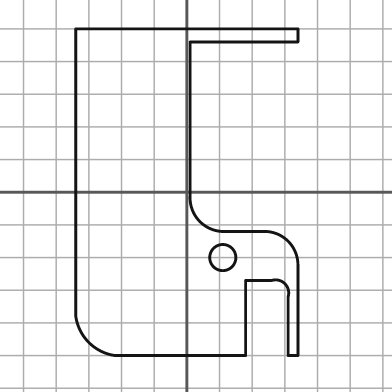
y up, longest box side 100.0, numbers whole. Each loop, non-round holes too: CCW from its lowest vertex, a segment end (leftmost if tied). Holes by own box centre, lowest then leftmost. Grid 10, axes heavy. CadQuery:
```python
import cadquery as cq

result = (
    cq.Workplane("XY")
    .moveTo(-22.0, -50.0)
    .lineTo(18.0, -50.0)
    .lineTo(18.0, -27.0)
    .lineTo(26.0, -27.0)
    .threePointArc((30.0, -28.0), (31.0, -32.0))
    .lineTo(31.0, -50.0)
    .lineTo(34.0, -50.0)
    .lineTo(34.0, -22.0)
    .threePointArc((31.0, -15.0), (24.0, -12.0))
    .lineTo(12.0, -12.0)
    .threePointArc((4.0, -9.0), (1.0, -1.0))
    .lineTo(1.0, 46.0)
    .lineTo(34.0, 46.0)
    .lineTo(34.0, 50.0)
    .lineTo(-34.0, 50.0)
    .lineTo(-34.0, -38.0)
    .threePointArc((-30.0, -46.0), (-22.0, -50.0))
    .close()
    .moveTo(11.0, -20.0)
    .circle(4.0)
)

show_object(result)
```